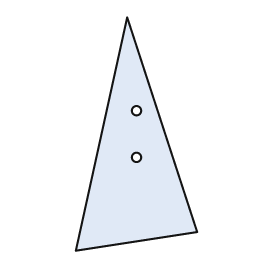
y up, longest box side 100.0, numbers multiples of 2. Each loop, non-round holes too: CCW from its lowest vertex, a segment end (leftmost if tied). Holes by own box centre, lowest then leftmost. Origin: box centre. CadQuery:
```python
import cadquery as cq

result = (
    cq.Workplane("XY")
    .moveTo(-26.0, -50.0)
    .lineTo(26.0, -42.0)
    .lineTo(-4.0, 50.0)
    .close()
    .moveTo(0.0, -10.0)
    .circle(2.0)
    .moveTo(0.0, 10.0)
    .circle(2.0)
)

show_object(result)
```